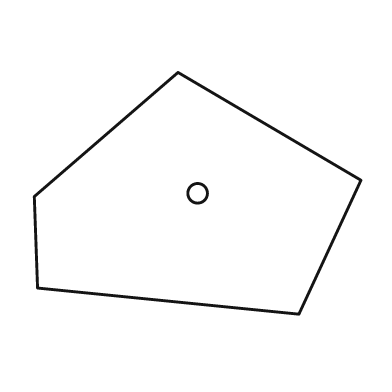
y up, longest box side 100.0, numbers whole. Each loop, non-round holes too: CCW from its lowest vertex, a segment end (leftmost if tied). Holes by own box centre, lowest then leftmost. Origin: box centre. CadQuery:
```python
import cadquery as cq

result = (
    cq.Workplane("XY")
    .moveTo(31.0, -37.0)
    .lineTo(50.0, 4.0)
    .lineTo(-6.0, 37.0)
    .lineTo(-50.0, -1.0)
    .lineTo(-49.0, -29.0)
    .close()
    .moveTo(0.0, 0.0)
    .circle(3.0)
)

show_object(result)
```